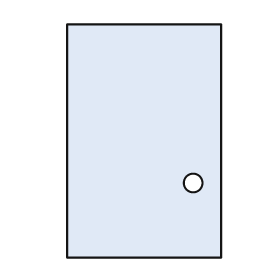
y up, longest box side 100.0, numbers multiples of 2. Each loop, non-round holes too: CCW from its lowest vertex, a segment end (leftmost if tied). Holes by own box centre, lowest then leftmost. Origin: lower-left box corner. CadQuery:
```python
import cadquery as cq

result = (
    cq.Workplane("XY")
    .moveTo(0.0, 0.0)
    .lineTo(66.0, 0.0)
    .lineTo(66.0, 100.0)
    .lineTo(0.0, 100.0)
    .close()
    .moveTo(54.0, 32.0)
    .circle(4.0)
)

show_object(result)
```